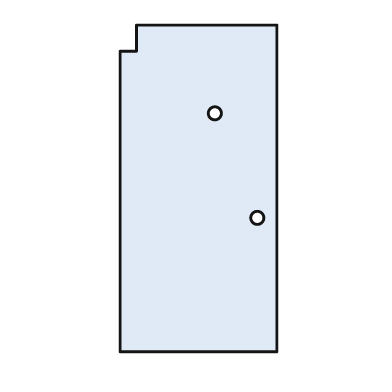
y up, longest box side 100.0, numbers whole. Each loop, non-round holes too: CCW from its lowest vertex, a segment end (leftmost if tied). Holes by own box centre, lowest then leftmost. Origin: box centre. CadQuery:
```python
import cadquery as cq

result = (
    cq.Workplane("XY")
    .moveTo(-24.0, -50.0)
    .lineTo(24.0, -50.0)
    .lineTo(24.0, 50.0)
    .lineTo(-19.0, 50.0)
    .lineTo(-19.0, 42.0)
    .lineTo(-24.0, 42.0)
    .close()
    .moveTo(18.0, -9.0)
    .circle(2.0)
    .moveTo(5.0, 23.0)
    .circle(2.0)
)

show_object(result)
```